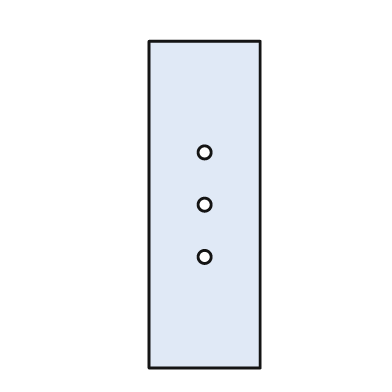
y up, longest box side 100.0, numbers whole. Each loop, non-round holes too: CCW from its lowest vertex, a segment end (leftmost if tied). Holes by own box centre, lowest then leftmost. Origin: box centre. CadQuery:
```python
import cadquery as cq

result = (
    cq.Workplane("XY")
    .moveTo(-17.0, -50.0)
    .lineTo(17.0, -50.0)
    .lineTo(17.0, 50.0)
    .lineTo(-17.0, 50.0)
    .close()
    .moveTo(0.0, -16.0)
    .circle(2.0)
    .moveTo(0.0, 0.0)
    .circle(2.0)
    .moveTo(0.0, 16.0)
    .circle(2.0)
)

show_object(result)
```